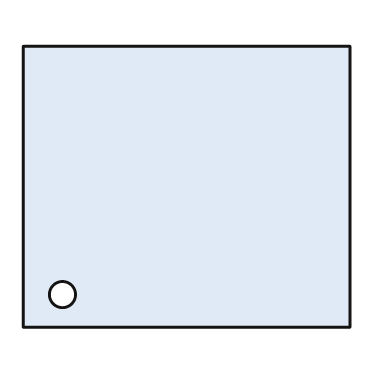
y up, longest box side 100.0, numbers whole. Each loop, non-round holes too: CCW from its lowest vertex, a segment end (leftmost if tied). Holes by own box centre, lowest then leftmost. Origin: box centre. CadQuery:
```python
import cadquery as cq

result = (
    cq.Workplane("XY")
    .moveTo(-50.0, -43.0)
    .lineTo(50.0, -43.0)
    .lineTo(50.0, 43.0)
    .lineTo(-50.0, 43.0)
    .close()
    .moveTo(-38.0, -33.0)
    .circle(4.0)
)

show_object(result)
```